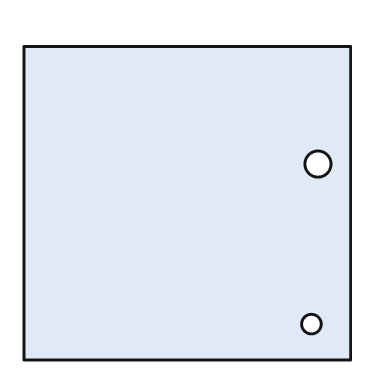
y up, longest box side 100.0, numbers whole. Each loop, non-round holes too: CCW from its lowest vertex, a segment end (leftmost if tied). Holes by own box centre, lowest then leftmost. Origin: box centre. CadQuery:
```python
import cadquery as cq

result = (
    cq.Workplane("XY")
    .moveTo(-50.0, -48.0)
    .lineTo(50.0, -48.0)
    .lineTo(50.0, 48.0)
    .lineTo(-50.0, 48.0)
    .close()
    .moveTo(38.0, -37.0)
    .circle(3.0)
    .moveTo(40.0, 12.0)
    .circle(4.0)
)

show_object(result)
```